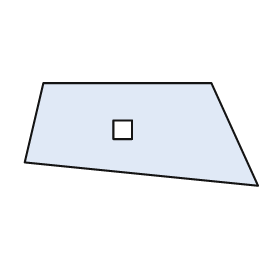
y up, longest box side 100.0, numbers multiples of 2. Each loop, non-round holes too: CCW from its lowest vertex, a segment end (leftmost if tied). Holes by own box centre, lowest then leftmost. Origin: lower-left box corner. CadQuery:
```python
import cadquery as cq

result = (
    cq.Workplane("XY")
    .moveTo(100.0, 0.0)
    .lineTo(80.0, 44.0)
    .lineTo(8.0, 44.0)
    .lineTo(0.0, 10.0)
    .close()
    .moveTo(38.0, 20.0)
    .lineTo(46.0, 20.0)
    .lineTo(46.0, 28.0)
    .lineTo(38.0, 28.0)
    .close()
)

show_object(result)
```